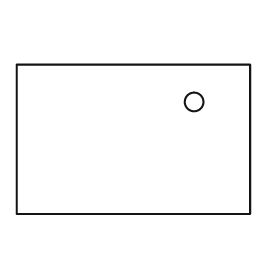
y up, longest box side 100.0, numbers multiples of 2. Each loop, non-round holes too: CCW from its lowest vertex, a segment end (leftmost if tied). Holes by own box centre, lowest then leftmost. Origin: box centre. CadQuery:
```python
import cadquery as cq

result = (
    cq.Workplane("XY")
    .moveTo(-50.0, -32.0)
    .lineTo(50.0, -32.0)
    .lineTo(50.0, 32.0)
    .lineTo(-50.0, 32.0)
    .close()
    .moveTo(26.0, 16.0)
    .circle(4.0)
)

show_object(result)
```